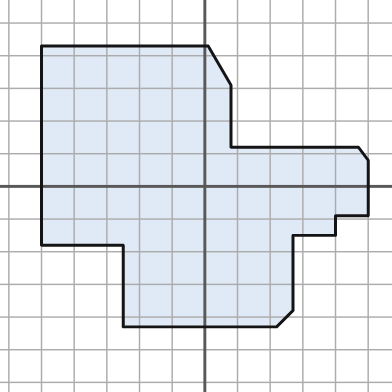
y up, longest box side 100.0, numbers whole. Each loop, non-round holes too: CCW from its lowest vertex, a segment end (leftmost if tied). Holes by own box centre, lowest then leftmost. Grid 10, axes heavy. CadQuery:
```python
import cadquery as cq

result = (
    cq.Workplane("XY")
    .moveTo(-25.0, -43.0)
    .lineTo(22.0, -43.0)
    .lineTo(27.0, -38.0)
    .lineTo(27.0, -15.0)
    .lineTo(40.0, -15.0)
    .lineTo(40.0, -9.0)
    .lineTo(50.0, -9.0)
    .lineTo(50.0, 8.0)
    .lineTo(47.0, 12.0)
    .lineTo(8.0, 12.0)
    .lineTo(8.0, 31.0)
    .lineTo(1.0, 43.0)
    .lineTo(-50.0, 43.0)
    .lineTo(-50.0, -18.0)
    .lineTo(-25.0, -18.0)
    .close()
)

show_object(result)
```